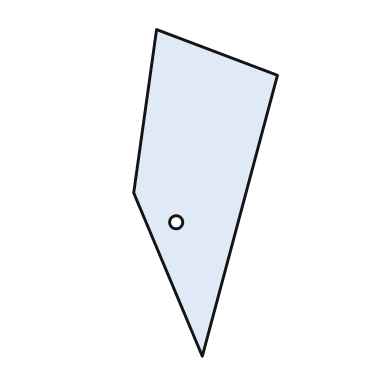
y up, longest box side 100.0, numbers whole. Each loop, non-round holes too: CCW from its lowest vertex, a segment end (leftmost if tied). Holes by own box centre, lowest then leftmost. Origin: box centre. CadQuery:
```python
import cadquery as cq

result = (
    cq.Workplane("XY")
    .moveTo(-1.0, -50.0)
    .lineTo(22.0, 36.0)
    .lineTo(-15.0, 50.0)
    .lineTo(-22.0, 0.0)
    .close()
    .moveTo(-9.0, -9.0)
    .circle(2.0)
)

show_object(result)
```